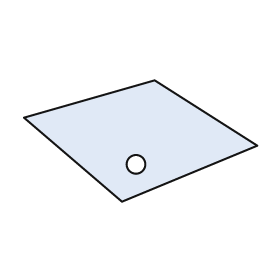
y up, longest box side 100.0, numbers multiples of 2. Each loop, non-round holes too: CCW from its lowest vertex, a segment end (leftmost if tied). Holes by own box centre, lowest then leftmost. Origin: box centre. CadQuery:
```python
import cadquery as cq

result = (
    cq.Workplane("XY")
    .moveTo(-8.0, -26.0)
    .lineTo(50.0, -2.0)
    .lineTo(6.0, 26.0)
    .lineTo(-50.0, 10.0)
    .close()
    .moveTo(-2.0, -10.0)
    .circle(4.0)
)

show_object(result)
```